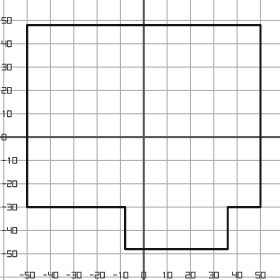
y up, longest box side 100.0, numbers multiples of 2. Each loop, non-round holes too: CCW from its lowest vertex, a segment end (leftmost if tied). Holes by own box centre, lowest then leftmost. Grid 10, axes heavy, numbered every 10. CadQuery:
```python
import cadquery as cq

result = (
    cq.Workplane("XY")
    .moveTo(-8.0, -48.0)
    .lineTo(36.0, -48.0)
    .lineTo(36.0, -30.0)
    .lineTo(50.0, -30.0)
    .lineTo(50.0, 48.0)
    .lineTo(-50.0, 48.0)
    .lineTo(-50.0, -30.0)
    .lineTo(-8.0, -30.0)
    .close()
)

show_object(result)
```